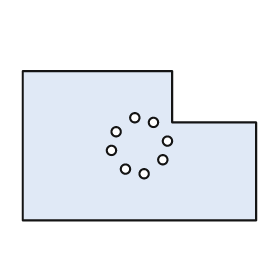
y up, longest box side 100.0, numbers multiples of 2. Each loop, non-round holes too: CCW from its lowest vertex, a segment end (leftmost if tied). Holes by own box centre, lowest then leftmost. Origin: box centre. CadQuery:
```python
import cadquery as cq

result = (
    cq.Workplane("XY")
    .moveTo(-50.0, -32.0)
    .lineTo(50.0, -32.0)
    .lineTo(50.0, 10.0)
    .lineTo(14.0, 10.0)
    .lineTo(14.0, 32.0)
    .lineTo(-50.0, 32.0)
    .close()
    .moveTo(2.0, -12.0)
    .circle(2.0)
    .moveTo(-6.0, -10.0)
    .circle(2.0)
    .moveTo(10.0, -6.0)
    .circle(2.0)
    .moveTo(-12.0, -2.0)
    .circle(2.0)
    .moveTo(12.0, 2.0)
    .circle(2.0)
    .moveTo(-10.0, 6.0)
    .circle(2.0)
    .moveTo(6.0, 10.0)
    .circle(2.0)
    .moveTo(-2.0, 12.0)
    .circle(2.0)
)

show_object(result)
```